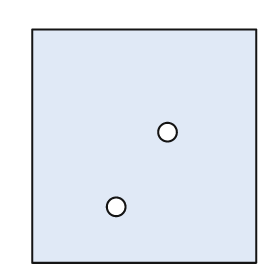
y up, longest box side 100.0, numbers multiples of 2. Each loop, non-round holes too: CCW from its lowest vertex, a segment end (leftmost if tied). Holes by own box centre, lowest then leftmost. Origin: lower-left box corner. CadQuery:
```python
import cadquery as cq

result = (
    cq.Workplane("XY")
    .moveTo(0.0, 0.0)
    .lineTo(96.0, 0.0)
    .lineTo(96.0, 100.0)
    .lineTo(0.0, 100.0)
    .close()
    .moveTo(36.0, 24.0)
    .circle(4.0)
    .moveTo(58.0, 56.0)
    .circle(4.0)
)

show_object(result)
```